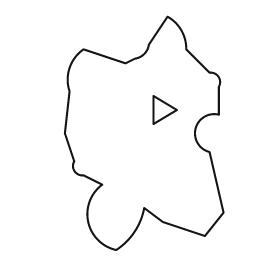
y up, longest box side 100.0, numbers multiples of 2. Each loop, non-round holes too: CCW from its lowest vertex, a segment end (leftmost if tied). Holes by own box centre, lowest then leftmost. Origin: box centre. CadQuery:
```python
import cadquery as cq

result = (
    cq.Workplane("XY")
    .moveTo(-12.0, -50.0)
    .threePointArc((-4.0, -42.0), (0.0, -32.0))
    .lineTo(8.0, -38.0)
    .lineTo(26.0, -44.0)
    .lineTo(34.0, -34.0)
    .lineTo(28.0, -8.0)
    .threePointArc((22.0, 2.0), (32.0, 8.0))
    .lineTo(32.0, 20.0)
    .threePointArc((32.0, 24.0), (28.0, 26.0))
    .lineTo(18.0, 36.0)
    .threePointArc((16.0, 44.0), (10.0, 50.0))
    .lineTo(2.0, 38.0)
    .threePointArc((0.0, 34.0), (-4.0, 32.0))
    .lineTo(-8.0, 30.0)
    .lineTo(-26.0, 36.0)
    .threePointArc((-32.0, 28.0), (-32.0, 18.0))
    .lineTo(-34.0, 0.0)
    .lineTo(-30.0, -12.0)
    .threePointArc((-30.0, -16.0), (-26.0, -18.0))
    .lineTo(-18.0, -22.0)
    .threePointArc((-24.0, -38.0), (-12.0, -50.0))
    .close()
    .moveTo(4.0, 4.0)
    .lineTo(14.0, 10.0)
    .lineTo(4.0, 16.0)
    .close()
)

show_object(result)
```